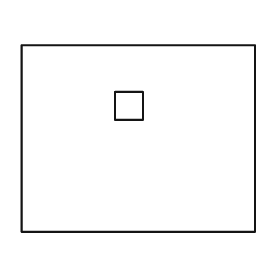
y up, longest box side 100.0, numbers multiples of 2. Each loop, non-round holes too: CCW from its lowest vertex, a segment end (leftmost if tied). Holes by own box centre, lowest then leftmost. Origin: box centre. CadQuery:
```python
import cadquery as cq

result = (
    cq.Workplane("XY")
    .moveTo(-50.0, -40.0)
    .lineTo(50.0, -40.0)
    .lineTo(50.0, 40.0)
    .lineTo(-50.0, 40.0)
    .close()
    .moveTo(-10.0, 8.0)
    .lineTo(2.0, 8.0)
    .lineTo(2.0, 20.0)
    .lineTo(-10.0, 20.0)
    .close()
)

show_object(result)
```